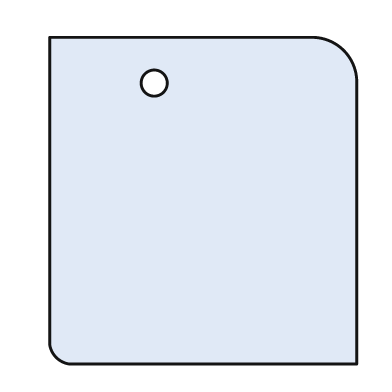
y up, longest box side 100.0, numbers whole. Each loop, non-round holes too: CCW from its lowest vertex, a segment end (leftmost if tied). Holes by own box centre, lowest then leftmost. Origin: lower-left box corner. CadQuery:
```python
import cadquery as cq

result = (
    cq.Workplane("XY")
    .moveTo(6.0, 0.0)
    .lineTo(94.0, 0.0)
    .lineTo(94.0, 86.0)
    .threePointArc((90.0, 96.0), (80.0, 100.0))
    .lineTo(0.0, 100.0)
    .lineTo(0.0, 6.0)
    .threePointArc((2.0, 2.0), (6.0, 0.0))
    .close()
    .moveTo(32.0, 86.0)
    .circle(4.0)
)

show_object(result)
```